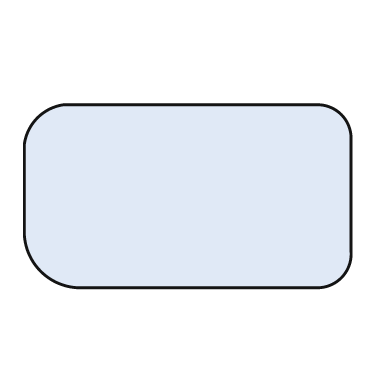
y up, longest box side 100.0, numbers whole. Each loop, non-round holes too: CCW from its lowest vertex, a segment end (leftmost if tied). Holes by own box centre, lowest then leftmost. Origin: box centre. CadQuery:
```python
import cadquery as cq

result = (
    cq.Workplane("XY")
    .moveTo(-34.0, -28.0)
    .lineTo(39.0, -28.0)
    .threePointArc((47.0, -25.0), (50.0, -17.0))
    .lineTo(50.0, 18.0)
    .threePointArc((47.0, 25.0), (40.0, 28.0))
    .lineTo(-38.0, 28.0)
    .threePointArc((-46.0, 24.0), (-50.0, 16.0))
    .lineTo(-50.0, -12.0)
    .threePointArc((-45.0, -23.0), (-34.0, -28.0))
    .close()
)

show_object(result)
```